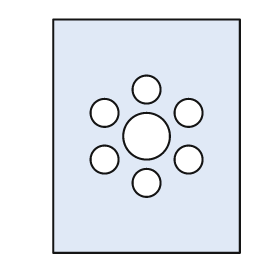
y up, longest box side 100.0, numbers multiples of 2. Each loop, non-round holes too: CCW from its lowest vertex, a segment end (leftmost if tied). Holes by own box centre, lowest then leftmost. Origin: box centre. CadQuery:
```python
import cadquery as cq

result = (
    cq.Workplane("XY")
    .moveTo(-40.0, -50.0)
    .lineTo(40.0, -50.0)
    .lineTo(40.0, 50.0)
    .lineTo(-40.0, 50.0)
    .close()
    .moveTo(0.0, -20.0)
    .circle(6.0)
    .moveTo(-18.0, -10.0)
    .circle(6.0)
    .moveTo(18.0, -10.0)
    .circle(6.0)
    .moveTo(0.0, 0.0)
    .circle(10.0)
    .moveTo(-18.0, 10.0)
    .circle(6.0)
    .moveTo(18.0, 10.0)
    .circle(6.0)
    .moveTo(0.0, 20.0)
    .circle(6.0)
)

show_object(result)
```